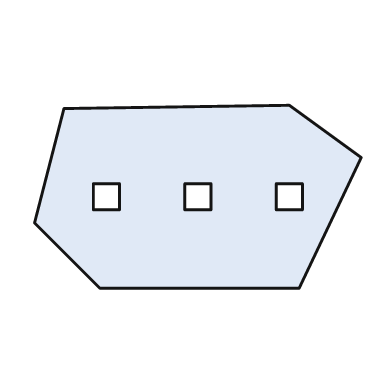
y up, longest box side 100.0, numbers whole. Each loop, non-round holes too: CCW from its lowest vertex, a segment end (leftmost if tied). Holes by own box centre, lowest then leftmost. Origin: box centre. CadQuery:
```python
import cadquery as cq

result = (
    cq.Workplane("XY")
    .moveTo(-30.0, -28.0)
    .lineTo(31.0, -28.0)
    .lineTo(50.0, 12.0)
    .lineTo(28.0, 28.0)
    .lineTo(-41.0, 27.0)
    .lineTo(-50.0, -8.0)
    .close()
    .moveTo(-32.0, -4.0)
    .lineTo(-24.0, -4.0)
    .lineTo(-24.0, 4.0)
    .lineTo(-32.0, 4.0)
    .close()
    .moveTo(-4.0, -4.0)
    .lineTo(4.0, -4.0)
    .lineTo(4.0, 4.0)
    .lineTo(-4.0, 4.0)
    .close()
    .moveTo(24.0, -4.0)
    .lineTo(32.0, -4.0)
    .lineTo(32.0, 4.0)
    .lineTo(24.0, 4.0)
    .close()
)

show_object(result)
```